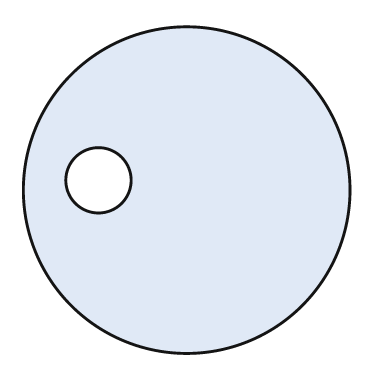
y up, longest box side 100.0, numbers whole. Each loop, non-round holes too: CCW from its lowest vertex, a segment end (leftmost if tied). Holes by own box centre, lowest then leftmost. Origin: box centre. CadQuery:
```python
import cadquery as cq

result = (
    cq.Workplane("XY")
    .moveTo(0.0, 0.0)
    .circle(50.0)
    .moveTo(-27.0, 3.0)
    .circle(10.0)
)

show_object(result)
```